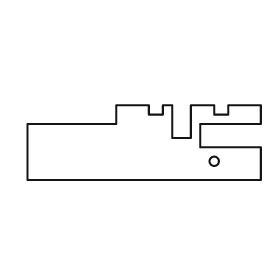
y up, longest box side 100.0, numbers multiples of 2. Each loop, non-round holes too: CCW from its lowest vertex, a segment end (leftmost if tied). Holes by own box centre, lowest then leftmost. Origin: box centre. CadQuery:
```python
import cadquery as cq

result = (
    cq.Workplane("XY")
    .moveTo(-50.0, -16.0)
    .lineTo(50.0, -16.0)
    .lineTo(50.0, -2.0)
    .lineTo(24.0, -2.0)
    .lineTo(24.0, 8.0)
    .lineTo(50.0, 8.0)
    .lineTo(50.0, 16.0)
    .lineTo(36.0, 16.0)
    .lineTo(36.0, 12.0)
    .lineTo(30.0, 12.0)
    .lineTo(30.0, 16.0)
    .lineTo(20.0, 16.0)
    .lineTo(20.0, 2.0)
    .lineTo(12.0, 2.0)
    .lineTo(12.0, 16.0)
    .lineTo(8.0, 16.0)
    .lineTo(8.0, 12.0)
    .lineTo(2.0, 12.0)
    .lineTo(2.0, 16.0)
    .lineTo(-12.0, 16.0)
    .lineTo(-12.0, 8.0)
    .lineTo(-50.0, 8.0)
    .close()
    .moveTo(30.0, -8.0)
    .circle(2.0)
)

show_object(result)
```